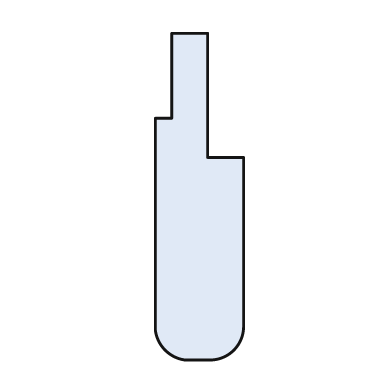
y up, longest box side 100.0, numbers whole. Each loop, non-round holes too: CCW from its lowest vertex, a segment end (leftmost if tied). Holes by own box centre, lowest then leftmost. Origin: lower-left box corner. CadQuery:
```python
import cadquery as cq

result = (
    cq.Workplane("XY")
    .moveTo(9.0, 0.0)
    .lineTo(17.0, 0.0)
    .threePointArc((24.0, 3.0), (27.0, 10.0))
    .lineTo(27.0, 62.0)
    .lineTo(16.0, 62.0)
    .lineTo(16.0, 100.0)
    .lineTo(5.0, 100.0)
    .lineTo(5.0, 74.0)
    .lineTo(0.0, 74.0)
    .lineTo(0.0, 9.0)
    .threePointArc((3.0, 3.0), (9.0, 0.0))
    .close()
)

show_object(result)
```